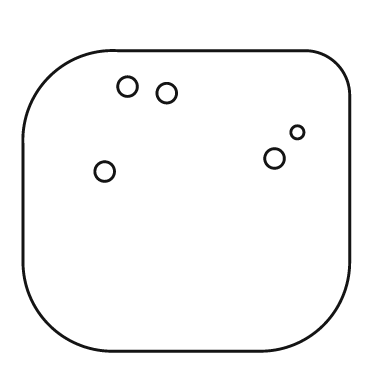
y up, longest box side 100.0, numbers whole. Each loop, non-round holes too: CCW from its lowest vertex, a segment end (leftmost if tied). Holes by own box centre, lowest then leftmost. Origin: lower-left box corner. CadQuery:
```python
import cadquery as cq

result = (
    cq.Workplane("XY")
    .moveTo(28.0, 0.0)
    .lineTo(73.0, 0.0)
    .threePointArc((92.0, 8.0), (100.0, 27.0))
    .lineTo(100.0, 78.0)
    .threePointArc((96.0, 88.0), (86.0, 92.0))
    .lineTo(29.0, 92.0)
    .threePointArc((8.0, 84.0), (0.0, 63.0))
    .lineTo(0.0, 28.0)
    .threePointArc((8.0, 8.0), (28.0, 0.0))
    .close()
    .moveTo(25.0, 55.0)
    .circle(3.0)
    .moveTo(77.0, 59.0)
    .circle(3.0)
    .moveTo(84.0, 67.0)
    .circle(2.0)
    .moveTo(44.0, 79.0)
    .circle(3.0)
    .moveTo(32.0, 81.0)
    .circle(3.0)
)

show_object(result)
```